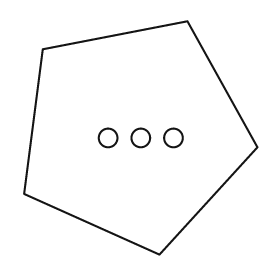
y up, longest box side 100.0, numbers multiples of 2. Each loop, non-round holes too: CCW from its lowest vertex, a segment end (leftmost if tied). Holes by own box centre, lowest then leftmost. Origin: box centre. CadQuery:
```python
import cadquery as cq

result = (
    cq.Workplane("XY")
    .moveTo(8.0, -50.0)
    .lineTo(50.0, -4.0)
    .lineTo(20.0, 50.0)
    .lineTo(-42.0, 38.0)
    .lineTo(-50.0, -24.0)
    .close()
    .moveTo(-14.0, 0.0)
    .circle(4.0)
    .moveTo(0.0, 0.0)
    .circle(4.0)
    .moveTo(14.0, 0.0)
    .circle(4.0)
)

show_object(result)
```